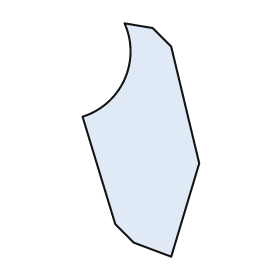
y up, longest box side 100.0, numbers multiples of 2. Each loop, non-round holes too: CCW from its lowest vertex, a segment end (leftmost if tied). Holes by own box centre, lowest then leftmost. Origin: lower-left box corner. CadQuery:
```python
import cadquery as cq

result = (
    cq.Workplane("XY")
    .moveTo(38.0, 0.0)
    .lineTo(50.0, 40.0)
    .lineTo(38.0, 90.0)
    .lineTo(30.0, 98.0)
    .lineTo(18.0, 100.0)
    .threePointArc((18.0, 76.0), (0.0, 60.0))
    .lineTo(14.0, 14.0)
    .lineTo(22.0, 6.0)
    .close()
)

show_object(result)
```